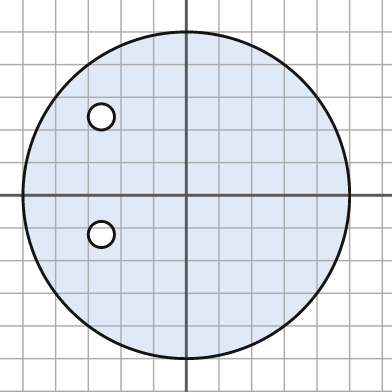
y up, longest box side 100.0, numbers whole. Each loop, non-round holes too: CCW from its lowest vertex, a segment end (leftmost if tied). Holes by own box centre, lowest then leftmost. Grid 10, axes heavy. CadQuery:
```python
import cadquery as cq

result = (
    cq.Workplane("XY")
    .moveTo(0.0, 0.0)
    .circle(50.0)
    .moveTo(-26.0, -12.0)
    .circle(4.0)
    .moveTo(-26.0, 24.0)
    .circle(4.0)
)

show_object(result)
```